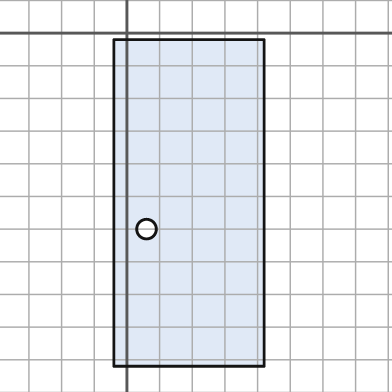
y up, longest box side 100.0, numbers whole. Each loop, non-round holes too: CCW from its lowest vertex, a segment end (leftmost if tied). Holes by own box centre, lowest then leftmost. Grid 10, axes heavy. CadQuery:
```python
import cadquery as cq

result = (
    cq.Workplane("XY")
    .moveTo(-4.0, -102.0)
    .lineTo(42.0, -102.0)
    .lineTo(42.0, -2.0)
    .lineTo(-4.0, -2.0)
    .close()
    .moveTo(6.0, -60.0)
    .circle(3.0)
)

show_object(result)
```